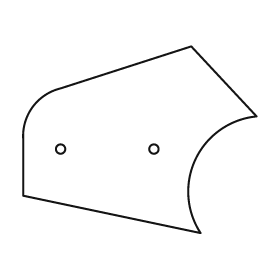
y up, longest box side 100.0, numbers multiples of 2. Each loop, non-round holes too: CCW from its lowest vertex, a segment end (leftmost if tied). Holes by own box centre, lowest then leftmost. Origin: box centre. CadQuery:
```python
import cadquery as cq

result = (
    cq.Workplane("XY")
    .moveTo(26.0, -40.0)
    .threePointArc((24.0, -8.0), (50.0, 10.0))
    .lineTo(22.0, 40.0)
    .lineTo(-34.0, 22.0)
    .threePointArc((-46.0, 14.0), (-50.0, 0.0))
    .lineTo(-50.0, -24.0)
    .close()
    .moveTo(-34.0, -4.0)
    .circle(2.0)
    .moveTo(6.0, -4.0)
    .circle(2.0)
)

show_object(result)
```